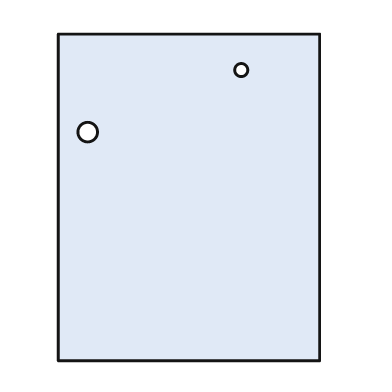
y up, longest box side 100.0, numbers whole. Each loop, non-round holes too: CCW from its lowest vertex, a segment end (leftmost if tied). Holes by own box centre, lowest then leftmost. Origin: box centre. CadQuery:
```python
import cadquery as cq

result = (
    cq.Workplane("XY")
    .moveTo(-40.0, -50.0)
    .lineTo(40.0, -50.0)
    .lineTo(40.0, 50.0)
    .lineTo(-40.0, 50.0)
    .close()
    .moveTo(-31.0, 20.0)
    .circle(3.0)
    .moveTo(16.0, 39.0)
    .circle(2.0)
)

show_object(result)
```